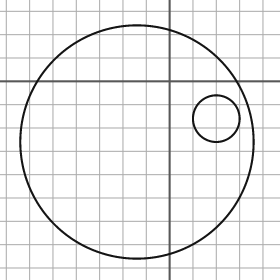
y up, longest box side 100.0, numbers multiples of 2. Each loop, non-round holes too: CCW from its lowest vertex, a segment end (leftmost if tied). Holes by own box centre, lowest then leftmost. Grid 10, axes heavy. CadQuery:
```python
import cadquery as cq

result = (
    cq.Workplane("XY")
    .moveTo(-14.0, -26.0)
    .circle(50.0)
    .moveTo(20.0, -16.0)
    .circle(10.0)
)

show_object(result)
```